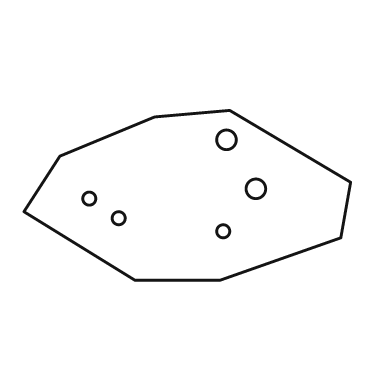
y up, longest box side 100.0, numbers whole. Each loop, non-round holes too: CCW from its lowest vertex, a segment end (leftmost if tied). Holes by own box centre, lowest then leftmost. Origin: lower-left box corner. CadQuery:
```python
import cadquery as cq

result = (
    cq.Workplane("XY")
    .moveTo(34.0, 0.0)
    .lineTo(60.0, 0.0)
    .lineTo(97.0, 13.0)
    .lineTo(100.0, 30.0)
    .lineTo(63.0, 52.0)
    .lineTo(40.0, 50.0)
    .lineTo(11.0, 38.0)
    .lineTo(0.0, 21.0)
    .close()
    .moveTo(61.0, 15.0)
    .circle(2.0)
    .moveTo(29.0, 19.0)
    .circle(2.0)
    .moveTo(20.0, 25.0)
    .circle(2.0)
    .moveTo(71.0, 28.0)
    .circle(3.0)
    .moveTo(62.0, 43.0)
    .circle(3.0)
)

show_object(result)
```